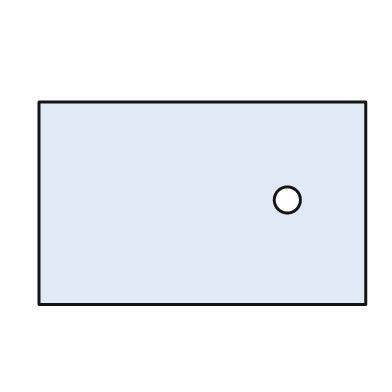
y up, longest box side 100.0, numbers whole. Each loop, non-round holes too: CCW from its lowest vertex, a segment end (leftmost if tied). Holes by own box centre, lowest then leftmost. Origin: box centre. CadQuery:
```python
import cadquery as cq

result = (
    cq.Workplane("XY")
    .moveTo(-50.0, -31.0)
    .lineTo(50.0, -31.0)
    .lineTo(50.0, 31.0)
    .lineTo(-50.0, 31.0)
    .close()
    .moveTo(26.0, 1.0)
    .circle(4.0)
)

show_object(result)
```